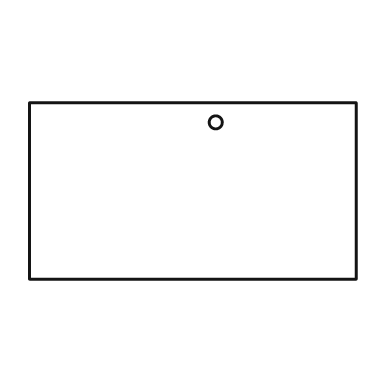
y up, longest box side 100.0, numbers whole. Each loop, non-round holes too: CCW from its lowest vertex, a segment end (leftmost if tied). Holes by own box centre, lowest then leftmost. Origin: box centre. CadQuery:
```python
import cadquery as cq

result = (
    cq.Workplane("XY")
    .moveTo(-50.0, -27.0)
    .lineTo(50.0, -27.0)
    .lineTo(50.0, 27.0)
    .lineTo(-50.0, 27.0)
    .close()
    .moveTo(7.0, 21.0)
    .circle(2.0)
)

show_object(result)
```